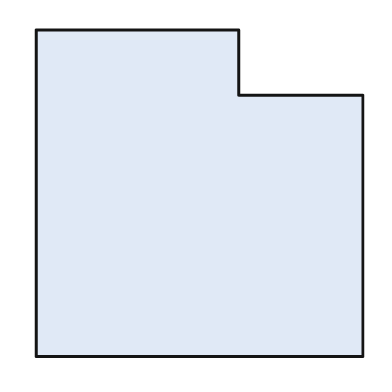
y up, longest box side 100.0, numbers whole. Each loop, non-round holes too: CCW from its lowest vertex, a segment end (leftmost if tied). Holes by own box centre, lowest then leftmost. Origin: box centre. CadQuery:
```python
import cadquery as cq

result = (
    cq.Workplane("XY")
    .moveTo(-50.0, -50.0)
    .lineTo(50.0, -50.0)
    .lineTo(50.0, 30.0)
    .lineTo(12.0, 30.0)
    .lineTo(12.0, 50.0)
    .lineTo(-50.0, 50.0)
    .close()
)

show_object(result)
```